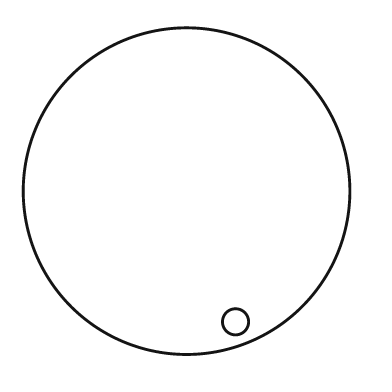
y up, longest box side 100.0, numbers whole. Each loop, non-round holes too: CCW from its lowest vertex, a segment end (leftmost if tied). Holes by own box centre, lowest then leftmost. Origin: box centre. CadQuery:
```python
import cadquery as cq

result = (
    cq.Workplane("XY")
    .moveTo(0.0, 0.0)
    .circle(50.0)
    .moveTo(15.0, -40.0)
    .circle(4.0)
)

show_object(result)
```